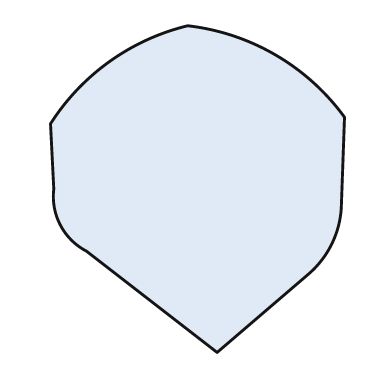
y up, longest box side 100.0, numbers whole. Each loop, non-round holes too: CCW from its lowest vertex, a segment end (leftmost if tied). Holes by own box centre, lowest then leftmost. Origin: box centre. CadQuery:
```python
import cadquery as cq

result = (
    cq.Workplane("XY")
    .moveTo(6.0, -50.0)
    .lineTo(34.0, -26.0)
    .threePointArc((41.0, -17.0), (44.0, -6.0))
    .lineTo(45.0, 22.0)
    .threePointArc((24.0, 41.0), (-3.0, 50.0))
    .threePointArc((-27.0, 39.0), (-45.0, 20.0))
    .lineTo(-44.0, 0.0)
    .threePointArc((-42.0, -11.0), (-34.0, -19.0))
    .close()
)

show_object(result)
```